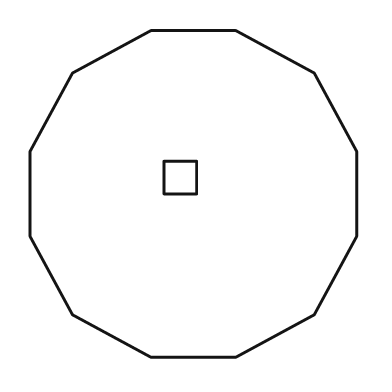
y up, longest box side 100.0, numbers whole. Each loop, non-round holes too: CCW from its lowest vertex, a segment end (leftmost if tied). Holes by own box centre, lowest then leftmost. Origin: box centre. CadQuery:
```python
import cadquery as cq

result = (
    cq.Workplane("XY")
    .moveTo(-13.0, -50.0)
    .lineTo(13.0, -50.0)
    .lineTo(37.0, -37.0)
    .lineTo(50.0, -13.0)
    .lineTo(50.0, 13.0)
    .lineTo(37.0, 37.0)
    .lineTo(13.0, 50.0)
    .lineTo(-13.0, 50.0)
    .lineTo(-37.0, 37.0)
    .lineTo(-50.0, 13.0)
    .lineTo(-50.0, -13.0)
    .lineTo(-37.0, -37.0)
    .close()
    .moveTo(-9.0, 0.0)
    .lineTo(1.0, 0.0)
    .lineTo(1.0, 10.0)
    .lineTo(-9.0, 10.0)
    .close()
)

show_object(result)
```